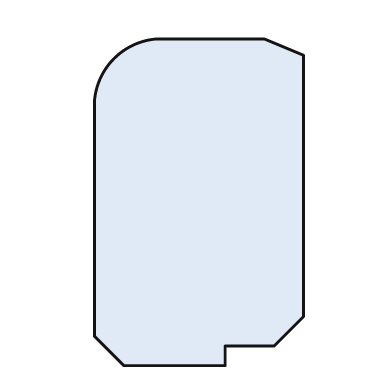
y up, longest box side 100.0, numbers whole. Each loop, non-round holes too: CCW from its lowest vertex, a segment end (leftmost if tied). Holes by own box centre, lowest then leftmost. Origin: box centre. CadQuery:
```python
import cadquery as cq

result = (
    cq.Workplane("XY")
    .moveTo(-23.0, -50.0)
    .lineTo(8.0, -50.0)
    .lineTo(8.0, -44.0)
    .lineTo(23.0, -44.0)
    .lineTo(32.0, -35.0)
    .lineTo(32.0, 45.0)
    .lineTo(20.0, 50.0)
    .lineTo(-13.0, 50.0)
    .threePointArc((-26.0, 44.0), (-32.0, 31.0))
    .lineTo(-32.0, -41.0)
    .close()
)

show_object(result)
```